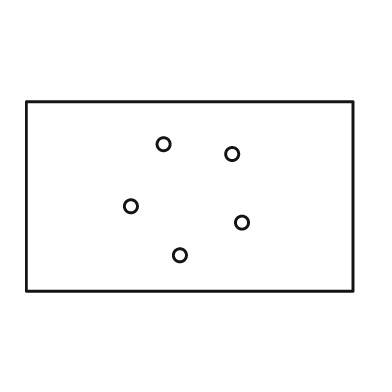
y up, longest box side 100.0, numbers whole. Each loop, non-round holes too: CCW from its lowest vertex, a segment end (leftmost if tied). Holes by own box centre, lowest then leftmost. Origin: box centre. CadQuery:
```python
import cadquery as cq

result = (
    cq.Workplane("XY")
    .moveTo(-50.0, -29.0)
    .lineTo(50.0, -29.0)
    .lineTo(50.0, 29.0)
    .lineTo(-50.0, 29.0)
    .close()
    .moveTo(-3.0, -18.0)
    .circle(2.0)
    .moveTo(16.0, -8.0)
    .circle(2.0)
    .moveTo(-18.0, -3.0)
    .circle(2.0)
    .moveTo(13.0, 13.0)
    .circle(2.0)
    .moveTo(-8.0, 16.0)
    .circle(2.0)
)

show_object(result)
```